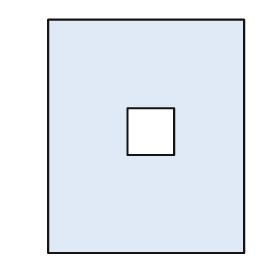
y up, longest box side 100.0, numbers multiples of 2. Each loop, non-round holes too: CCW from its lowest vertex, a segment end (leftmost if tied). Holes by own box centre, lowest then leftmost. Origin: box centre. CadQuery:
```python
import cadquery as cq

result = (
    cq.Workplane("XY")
    .moveTo(-42.0, -50.0)
    .lineTo(42.0, -50.0)
    .lineTo(42.0, 50.0)
    .lineTo(-42.0, 50.0)
    .close()
    .moveTo(-8.0, -8.0)
    .lineTo(12.0, -8.0)
    .lineTo(12.0, 12.0)
    .lineTo(-8.0, 12.0)
    .close()
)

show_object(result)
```